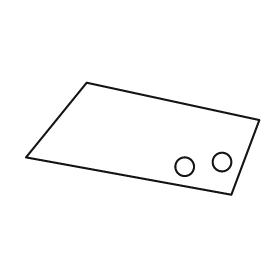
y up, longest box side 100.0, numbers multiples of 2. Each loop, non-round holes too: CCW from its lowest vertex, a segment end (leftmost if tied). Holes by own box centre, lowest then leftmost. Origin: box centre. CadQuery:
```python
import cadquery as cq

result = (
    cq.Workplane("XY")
    .moveTo(38.0, -24.0)
    .lineTo(50.0, 8.0)
    .lineTo(-24.0, 24.0)
    .lineTo(-50.0, -8.0)
    .close()
    .moveTo(18.0, -12.0)
    .circle(4.0)
    .moveTo(34.0, -10.0)
    .circle(4.0)
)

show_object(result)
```